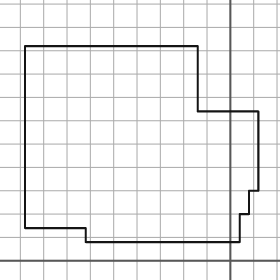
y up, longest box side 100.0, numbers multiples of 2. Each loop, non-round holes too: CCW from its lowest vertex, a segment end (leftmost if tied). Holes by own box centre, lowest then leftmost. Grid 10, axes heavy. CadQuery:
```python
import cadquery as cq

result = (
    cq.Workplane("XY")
    .moveTo(-62.0, 8.0)
    .lineTo(4.0, 8.0)
    .lineTo(4.0, 20.0)
    .lineTo(8.0, 20.0)
    .lineTo(8.0, 30.0)
    .lineTo(12.0, 30.0)
    .lineTo(12.0, 64.0)
    .lineTo(-14.0, 64.0)
    .lineTo(-14.0, 92.0)
    .lineTo(-88.0, 92.0)
    .lineTo(-88.0, 14.0)
    .lineTo(-62.0, 14.0)
    .close()
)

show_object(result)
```